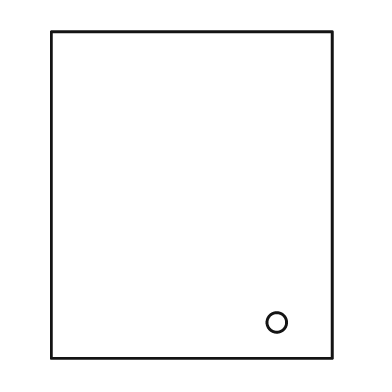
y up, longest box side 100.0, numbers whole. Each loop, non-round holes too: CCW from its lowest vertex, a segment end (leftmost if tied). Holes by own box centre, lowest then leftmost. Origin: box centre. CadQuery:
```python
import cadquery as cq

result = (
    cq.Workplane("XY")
    .moveTo(-43.0, -50.0)
    .lineTo(43.0, -50.0)
    .lineTo(43.0, 50.0)
    .lineTo(-43.0, 50.0)
    .close()
    .moveTo(26.0, -39.0)
    .circle(3.0)
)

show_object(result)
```